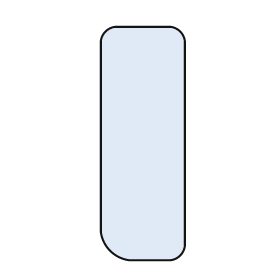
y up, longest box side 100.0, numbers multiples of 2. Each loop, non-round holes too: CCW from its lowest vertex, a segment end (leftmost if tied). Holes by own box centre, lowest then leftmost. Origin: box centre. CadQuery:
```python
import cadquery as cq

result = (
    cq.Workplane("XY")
    .moveTo(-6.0, -50.0)
    .lineTo(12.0, -50.0)
    .threePointArc((16.0, -48.0), (18.0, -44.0))
    .lineTo(18.0, 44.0)
    .threePointArc((16.0, 48.0), (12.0, 50.0))
    .lineTo(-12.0, 50.0)
    .threePointArc((-16.0, 48.0), (-18.0, 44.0))
    .lineTo(-18.0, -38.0)
    .threePointArc((-14.0, -46.0), (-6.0, -50.0))
    .close()
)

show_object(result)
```